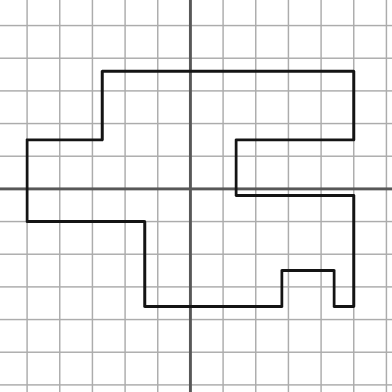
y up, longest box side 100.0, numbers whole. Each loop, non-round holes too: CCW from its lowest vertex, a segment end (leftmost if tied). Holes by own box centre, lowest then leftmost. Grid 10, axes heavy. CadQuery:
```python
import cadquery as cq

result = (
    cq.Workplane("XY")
    .moveTo(-14.0, -36.0)
    .lineTo(28.0, -36.0)
    .lineTo(28.0, -25.0)
    .lineTo(44.0, -25.0)
    .lineTo(44.0, -36.0)
    .lineTo(50.0, -36.0)
    .lineTo(50.0, -2.0)
    .lineTo(14.0, -2.0)
    .lineTo(14.0, 15.0)
    .lineTo(50.0, 15.0)
    .lineTo(50.0, 36.0)
    .lineTo(-27.0, 36.0)
    .lineTo(-27.0, 15.0)
    .lineTo(-50.0, 15.0)
    .lineTo(-50.0, -10.0)
    .lineTo(-14.0, -10.0)
    .close()
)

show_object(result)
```